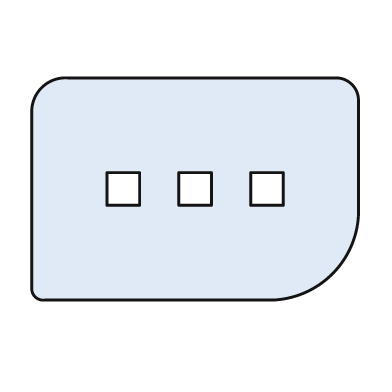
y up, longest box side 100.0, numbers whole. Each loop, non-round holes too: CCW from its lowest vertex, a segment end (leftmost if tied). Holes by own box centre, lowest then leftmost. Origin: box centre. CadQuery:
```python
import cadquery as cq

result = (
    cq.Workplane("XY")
    .moveTo(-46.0, -34.0)
    .lineTo(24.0, -34.0)
    .threePointArc((42.0, -26.0), (50.0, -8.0))
    .lineTo(50.0, 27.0)
    .threePointArc((48.0, 32.0), (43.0, 34.0))
    .lineTo(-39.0, 34.0)
    .threePointArc((-47.0, 31.0), (-50.0, 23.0))
    .lineTo(-50.0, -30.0)
    .threePointArc((-49.0, -33.0), (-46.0, -34.0))
    .close()
    .moveTo(-27.0, -5.0)
    .lineTo(-17.0, -5.0)
    .lineTo(-17.0, 5.0)
    .lineTo(-27.0, 5.0)
    .close()
    .moveTo(-5.0, -5.0)
    .lineTo(5.0, -5.0)
    .lineTo(5.0, 5.0)
    .lineTo(-5.0, 5.0)
    .close()
    .moveTo(17.0, -5.0)
    .lineTo(27.0, -5.0)
    .lineTo(27.0, 5.0)
    .lineTo(17.0, 5.0)
    .close()
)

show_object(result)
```